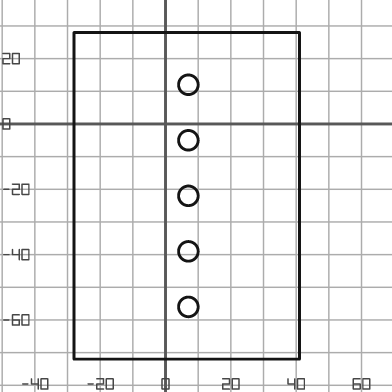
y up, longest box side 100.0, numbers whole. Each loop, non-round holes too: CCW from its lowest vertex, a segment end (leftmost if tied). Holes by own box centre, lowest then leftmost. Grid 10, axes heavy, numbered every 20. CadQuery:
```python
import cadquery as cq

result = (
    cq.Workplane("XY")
    .moveTo(-28.0, -72.0)
    .lineTo(41.0, -72.0)
    .lineTo(41.0, 28.0)
    .lineTo(-28.0, 28.0)
    .close()
    .moveTo(7.0, -56.0)
    .circle(3.0)
    .moveTo(7.0, -39.0)
    .circle(3.0)
    .moveTo(7.0, -22.0)
    .circle(3.0)
    .moveTo(7.0, -5.0)
    .circle(3.0)
    .moveTo(7.0, 12.0)
    .circle(3.0)
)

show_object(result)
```